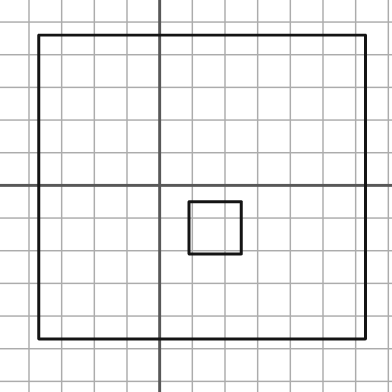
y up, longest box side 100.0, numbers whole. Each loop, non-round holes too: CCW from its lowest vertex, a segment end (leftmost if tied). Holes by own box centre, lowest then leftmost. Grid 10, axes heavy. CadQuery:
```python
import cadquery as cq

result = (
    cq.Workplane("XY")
    .moveTo(-37.0, -47.0)
    .lineTo(63.0, -47.0)
    .lineTo(63.0, 46.0)
    .lineTo(-37.0, 46.0)
    .close()
    .moveTo(9.0, -21.0)
    .lineTo(25.0, -21.0)
    .lineTo(25.0, -5.0)
    .lineTo(9.0, -5.0)
    .close()
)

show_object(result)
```